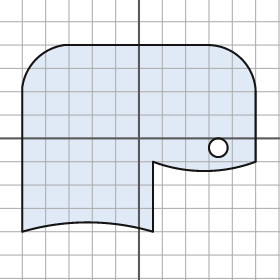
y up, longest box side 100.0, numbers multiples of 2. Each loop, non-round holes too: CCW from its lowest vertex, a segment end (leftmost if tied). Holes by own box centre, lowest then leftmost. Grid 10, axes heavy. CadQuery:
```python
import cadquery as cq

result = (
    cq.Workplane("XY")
    .moveTo(-50.0, -40.0)
    .threePointArc((-22.0, -36.0), (6.0, -40.0))
    .lineTo(6.0, -10.0)
    .threePointArc((28.0, -14.0), (50.0, -10.0))
    .lineTo(50.0, 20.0)
    .threePointArc((44.0, 34.0), (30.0, 40.0))
    .lineTo(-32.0, 40.0)
    .threePointArc((-44.0, 34.0), (-50.0, 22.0))
    .close()
    .moveTo(34.0, -4.0)
    .circle(4.0)
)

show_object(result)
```